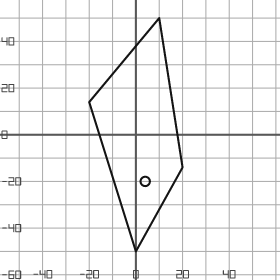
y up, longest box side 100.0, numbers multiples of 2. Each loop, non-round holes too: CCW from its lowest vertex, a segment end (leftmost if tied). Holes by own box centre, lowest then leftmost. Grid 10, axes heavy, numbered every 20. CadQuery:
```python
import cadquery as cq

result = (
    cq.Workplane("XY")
    .moveTo(0.0, -50.0)
    .lineTo(20.0, -14.0)
    .lineTo(10.0, 50.0)
    .lineTo(-20.0, 14.0)
    .close()
    .moveTo(4.0, -20.0)
    .circle(2.0)
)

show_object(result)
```